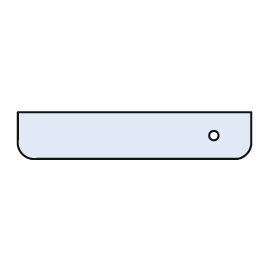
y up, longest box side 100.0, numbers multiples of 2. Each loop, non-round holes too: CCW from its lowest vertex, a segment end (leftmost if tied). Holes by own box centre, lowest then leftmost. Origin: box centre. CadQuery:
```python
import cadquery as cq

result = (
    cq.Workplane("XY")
    .moveTo(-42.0, -10.0)
    .lineTo(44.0, -10.0)
    .threePointArc((48.0, -8.0), (50.0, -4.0))
    .lineTo(50.0, 10.0)
    .lineTo(-50.0, 10.0)
    .lineTo(-50.0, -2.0)
    .threePointArc((-48.0, -8.0), (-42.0, -10.0))
    .close()
    .moveTo(34.0, 0.0)
    .circle(2.0)
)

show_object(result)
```